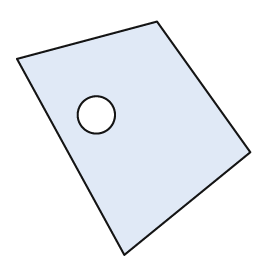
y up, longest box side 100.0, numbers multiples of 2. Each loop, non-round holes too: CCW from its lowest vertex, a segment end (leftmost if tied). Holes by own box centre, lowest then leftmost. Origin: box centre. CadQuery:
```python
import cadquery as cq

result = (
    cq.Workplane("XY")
    .moveTo(-4.0, -50.0)
    .lineTo(50.0, -6.0)
    .lineTo(10.0, 50.0)
    .lineTo(-50.0, 34.0)
    .close()
    .moveTo(-16.0, 10.0)
    .circle(8.0)
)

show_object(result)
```